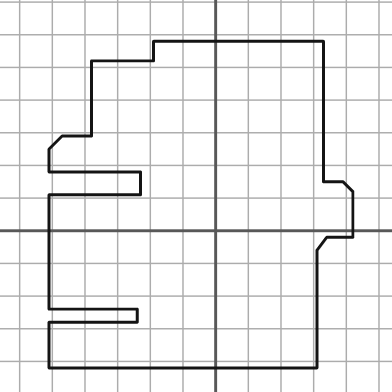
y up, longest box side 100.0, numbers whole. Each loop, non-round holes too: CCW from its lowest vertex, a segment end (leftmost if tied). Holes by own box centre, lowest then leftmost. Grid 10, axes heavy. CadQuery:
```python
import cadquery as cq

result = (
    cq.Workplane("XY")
    .moveTo(-51.0, -42.0)
    .lineTo(31.0, -42.0)
    .lineTo(31.0, -6.0)
    .lineTo(34.0, -2.0)
    .lineTo(42.0, -2.0)
    .lineTo(42.0, 12.0)
    .lineTo(39.0, 15.0)
    .lineTo(33.0, 15.0)
    .lineTo(33.0, 58.0)
    .lineTo(-19.0, 58.0)
    .lineTo(-19.0, 52.0)
    .lineTo(-38.0, 52.0)
    .lineTo(-38.0, 29.0)
    .lineTo(-47.0, 29.0)
    .lineTo(-51.0, 25.0)
    .lineTo(-51.0, 18.0)
    .lineTo(-23.0, 18.0)
    .lineTo(-23.0, 11.0)
    .lineTo(-51.0, 11.0)
    .lineTo(-51.0, -24.0)
    .lineTo(-24.0, -24.0)
    .lineTo(-24.0, -28.0)
    .lineTo(-51.0, -28.0)
    .close()
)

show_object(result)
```